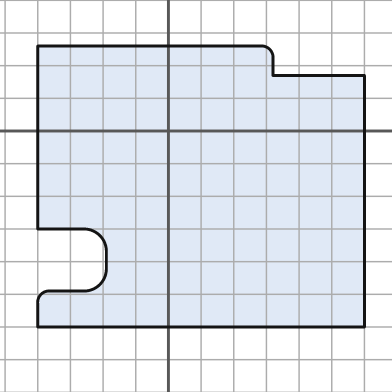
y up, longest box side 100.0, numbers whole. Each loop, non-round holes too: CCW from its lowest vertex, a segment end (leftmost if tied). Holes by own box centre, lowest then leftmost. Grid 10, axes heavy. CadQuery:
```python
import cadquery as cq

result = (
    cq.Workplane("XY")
    .moveTo(-40.0, -60.0)
    .lineTo(60.0, -60.0)
    .lineTo(60.0, 17.0)
    .lineTo(32.0, 17.0)
    .lineTo(32.0, 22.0)
    .threePointArc((31.0, 25.0), (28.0, 26.0))
    .lineTo(-40.0, 26.0)
    .lineTo(-40.0, -30.0)
    .lineTo(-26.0, -30.0)
    .threePointArc((-21.0, -32.0), (-19.0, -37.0))
    .lineTo(-19.0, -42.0)
    .threePointArc((-21.0, -47.0), (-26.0, -49.0))
    .lineTo(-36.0, -49.0)
    .threePointArc((-39.0, -50.0), (-40.0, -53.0))
    .close()
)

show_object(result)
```